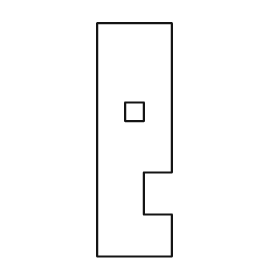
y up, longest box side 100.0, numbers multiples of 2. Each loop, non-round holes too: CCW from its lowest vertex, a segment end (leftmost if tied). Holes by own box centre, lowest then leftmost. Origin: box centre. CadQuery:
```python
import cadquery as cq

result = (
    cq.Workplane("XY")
    .moveTo(-16.0, -50.0)
    .lineTo(16.0, -50.0)
    .lineTo(16.0, -32.0)
    .lineTo(4.0, -32.0)
    .lineTo(4.0, -14.0)
    .lineTo(16.0, -14.0)
    .lineTo(16.0, 50.0)
    .lineTo(-16.0, 50.0)
    .close()
    .moveTo(-4.0, 8.0)
    .lineTo(4.0, 8.0)
    .lineTo(4.0, 16.0)
    .lineTo(-4.0, 16.0)
    .close()
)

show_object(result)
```